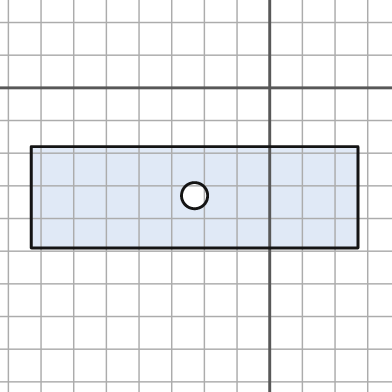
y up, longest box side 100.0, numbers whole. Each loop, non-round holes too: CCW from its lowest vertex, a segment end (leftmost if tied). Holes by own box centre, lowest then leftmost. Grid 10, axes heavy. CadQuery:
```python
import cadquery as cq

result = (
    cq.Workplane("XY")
    .moveTo(-73.0, -49.0)
    .lineTo(27.0, -49.0)
    .lineTo(27.0, -18.0)
    .lineTo(-73.0, -18.0)
    .close()
    .moveTo(-23.0, -33.0)
    .circle(4.0)
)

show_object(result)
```